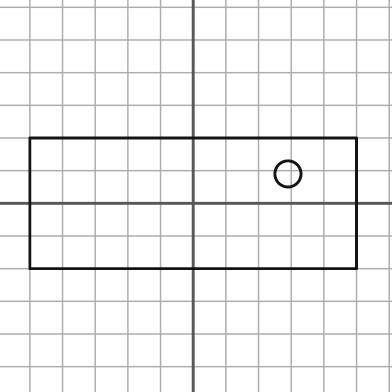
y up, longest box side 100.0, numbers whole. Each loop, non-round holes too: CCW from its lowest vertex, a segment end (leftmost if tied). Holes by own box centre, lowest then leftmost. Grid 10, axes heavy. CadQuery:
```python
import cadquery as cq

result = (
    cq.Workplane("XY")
    .moveTo(-50.0, -20.0)
    .lineTo(50.0, -20.0)
    .lineTo(50.0, 20.0)
    .lineTo(-50.0, 20.0)
    .close()
    .moveTo(29.0, 9.0)
    .circle(4.0)
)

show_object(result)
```